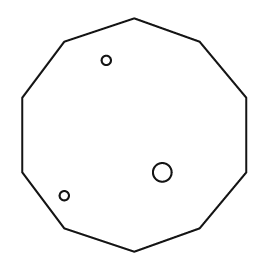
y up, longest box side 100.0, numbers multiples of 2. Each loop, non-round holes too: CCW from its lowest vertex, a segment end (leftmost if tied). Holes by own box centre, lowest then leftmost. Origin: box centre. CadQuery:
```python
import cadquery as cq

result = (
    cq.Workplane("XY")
    .moveTo(0.0, -50.0)
    .lineTo(28.0, -40.0)
    .lineTo(48.0, -16.0)
    .lineTo(48.0, 16.0)
    .lineTo(28.0, 40.0)
    .lineTo(0.0, 50.0)
    .lineTo(-30.0, 40.0)
    .lineTo(-48.0, 16.0)
    .lineTo(-48.0, -16.0)
    .lineTo(-30.0, -40.0)
    .close()
    .moveTo(-30.0, -26.0)
    .circle(2.0)
    .moveTo(12.0, -16.0)
    .circle(4.0)
    .moveTo(-12.0, 32.0)
    .circle(2.0)
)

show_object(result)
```